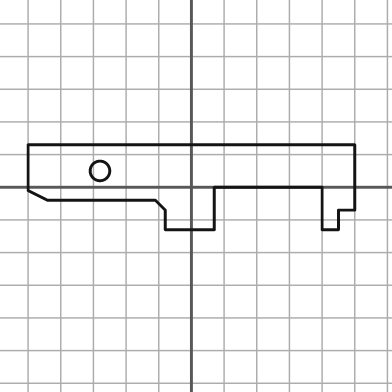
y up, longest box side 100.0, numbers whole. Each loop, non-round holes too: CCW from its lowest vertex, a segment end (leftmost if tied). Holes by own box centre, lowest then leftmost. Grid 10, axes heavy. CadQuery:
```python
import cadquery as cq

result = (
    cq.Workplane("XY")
    .moveTo(-8.0, -13.0)
    .lineTo(7.0, -13.0)
    .lineTo(7.0, 0.0)
    .lineTo(40.0, 0.0)
    .lineTo(40.0, -13.0)
    .lineTo(45.0, -13.0)
    .lineTo(45.0, -7.0)
    .lineTo(50.0, -7.0)
    .lineTo(50.0, 13.0)
    .lineTo(-50.0, 13.0)
    .lineTo(-50.0, -1.0)
    .lineTo(-44.0, -4.0)
    .lineTo(-11.0, -4.0)
    .lineTo(-8.0, -7.0)
    .close()
    .moveTo(-28.0, 5.0)
    .circle(3.0)
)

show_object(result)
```